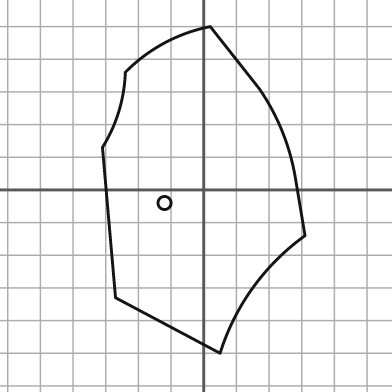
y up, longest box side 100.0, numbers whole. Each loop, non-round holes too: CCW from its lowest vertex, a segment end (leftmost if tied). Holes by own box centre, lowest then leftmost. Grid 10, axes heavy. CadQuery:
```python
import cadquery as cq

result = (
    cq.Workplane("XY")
    .moveTo(5.0, -50.0)
    .threePointArc((15.0, -30.0), (31.0, -14.0))
    .lineTo(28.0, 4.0)
    .threePointArc((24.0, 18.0), (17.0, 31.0))
    .lineTo(2.0, 50.0)
    .threePointArc((-12.0, 45.0), (-24.0, 36.0))
    .threePointArc((-26.0, 24.0), (-31.0, 13.0))
    .lineTo(-27.0, -33.0)
    .close()
    .moveTo(-12.0, -4.0)
    .circle(2.0)
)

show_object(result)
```